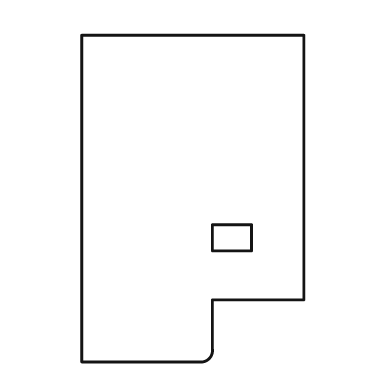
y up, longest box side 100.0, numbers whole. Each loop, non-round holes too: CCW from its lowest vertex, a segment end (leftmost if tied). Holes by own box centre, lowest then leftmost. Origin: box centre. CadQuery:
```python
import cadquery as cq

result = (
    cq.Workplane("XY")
    .moveTo(-34.0, -50.0)
    .lineTo(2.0, -50.0)
    .threePointArc((5.0, -49.0), (6.0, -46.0))
    .lineTo(6.0, -31.0)
    .lineTo(34.0, -31.0)
    .lineTo(34.0, 50.0)
    .lineTo(-34.0, 50.0)
    .close()
    .moveTo(6.0, -16.0)
    .lineTo(18.0, -16.0)
    .lineTo(18.0, -8.0)
    .lineTo(6.0, -8.0)
    .close()
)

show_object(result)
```